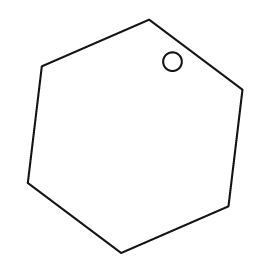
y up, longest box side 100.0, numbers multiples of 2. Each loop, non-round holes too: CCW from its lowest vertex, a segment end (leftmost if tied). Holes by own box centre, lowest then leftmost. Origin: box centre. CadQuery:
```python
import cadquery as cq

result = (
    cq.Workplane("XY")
    .moveTo(-6.0, -50.0)
    .lineTo(40.0, -30.0)
    .lineTo(46.0, 20.0)
    .lineTo(6.0, 50.0)
    .lineTo(-40.0, 30.0)
    .lineTo(-46.0, -20.0)
    .close()
    .moveTo(16.0, 32.0)
    .circle(4.0)
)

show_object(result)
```